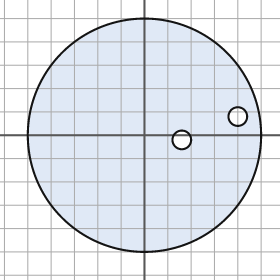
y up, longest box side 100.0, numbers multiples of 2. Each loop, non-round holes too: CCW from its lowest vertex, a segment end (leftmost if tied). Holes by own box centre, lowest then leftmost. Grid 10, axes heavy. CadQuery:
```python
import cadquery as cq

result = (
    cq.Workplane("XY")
    .moveTo(0.0, 0.0)
    .circle(50.0)
    .moveTo(16.0, -2.0)
    .circle(4.0)
    .moveTo(40.0, 8.0)
    .circle(4.0)
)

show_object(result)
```